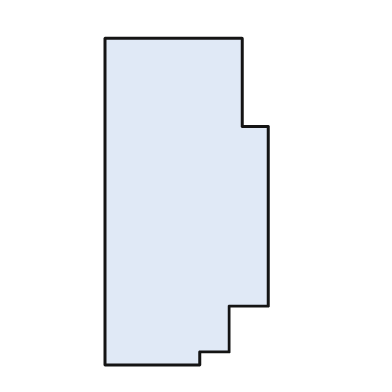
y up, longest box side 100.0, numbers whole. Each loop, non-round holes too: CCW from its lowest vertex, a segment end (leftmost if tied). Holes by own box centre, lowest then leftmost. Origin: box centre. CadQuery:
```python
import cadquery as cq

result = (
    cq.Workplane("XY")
    .moveTo(-25.0, -50.0)
    .lineTo(4.0, -50.0)
    .lineTo(4.0, -46.0)
    .lineTo(13.0, -46.0)
    .lineTo(13.0, -32.0)
    .lineTo(25.0, -32.0)
    .lineTo(25.0, 23.0)
    .lineTo(17.0, 23.0)
    .lineTo(17.0, 50.0)
    .lineTo(-25.0, 50.0)
    .close()
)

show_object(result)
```